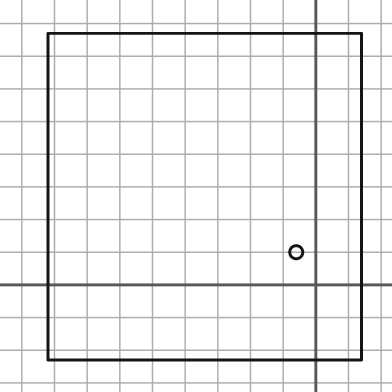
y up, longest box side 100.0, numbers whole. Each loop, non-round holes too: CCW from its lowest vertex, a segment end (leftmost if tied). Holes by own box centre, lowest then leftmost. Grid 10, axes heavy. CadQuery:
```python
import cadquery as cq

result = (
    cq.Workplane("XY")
    .moveTo(-82.0, -23.0)
    .lineTo(14.0, -23.0)
    .lineTo(14.0, 77.0)
    .lineTo(-82.0, 77.0)
    .close()
    .moveTo(-6.0, 10.0)
    .circle(2.0)
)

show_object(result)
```